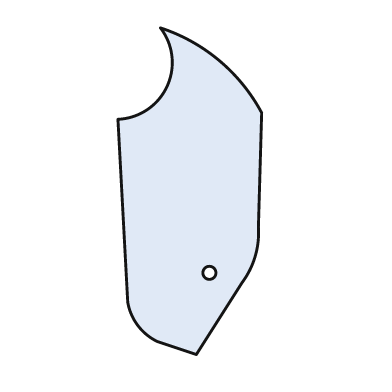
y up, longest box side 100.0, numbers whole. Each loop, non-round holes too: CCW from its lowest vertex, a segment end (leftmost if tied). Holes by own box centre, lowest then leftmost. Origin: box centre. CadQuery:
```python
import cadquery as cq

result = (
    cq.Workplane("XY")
    .moveTo(2.0, -50.0)
    .lineTo(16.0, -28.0)
    .threePointArc((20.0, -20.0), (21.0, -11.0))
    .lineTo(22.0, 24.0)
    .threePointArc((9.0, 40.0), (-9.0, 50.0))
    .threePointArc((-7.0, 32.0), (-22.0, 22.0))
    .lineTo(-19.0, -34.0)
    .threePointArc((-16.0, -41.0), (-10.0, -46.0))
    .close()
    .moveTo(6.0, -25.0)
    .circle(2.0)
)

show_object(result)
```